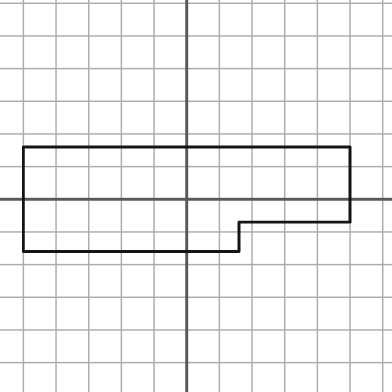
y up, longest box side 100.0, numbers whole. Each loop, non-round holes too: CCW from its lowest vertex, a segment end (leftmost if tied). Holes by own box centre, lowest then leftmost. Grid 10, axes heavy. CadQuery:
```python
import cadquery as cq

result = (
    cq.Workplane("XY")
    .moveTo(-50.0, -16.0)
    .lineTo(16.0, -16.0)
    .lineTo(16.0, -7.0)
    .lineTo(50.0, -7.0)
    .lineTo(50.0, 16.0)
    .lineTo(-50.0, 16.0)
    .close()
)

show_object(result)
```